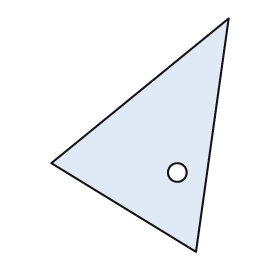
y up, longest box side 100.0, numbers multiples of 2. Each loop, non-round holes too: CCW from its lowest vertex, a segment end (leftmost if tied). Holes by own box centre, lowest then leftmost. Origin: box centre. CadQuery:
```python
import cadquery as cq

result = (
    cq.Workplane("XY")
    .moveTo(24.0, -50.0)
    .lineTo(38.0, 50.0)
    .lineTo(-38.0, -12.0)
    .close()
    .moveTo(16.0, -16.0)
    .circle(4.0)
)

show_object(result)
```